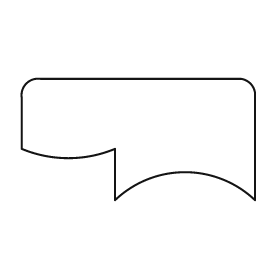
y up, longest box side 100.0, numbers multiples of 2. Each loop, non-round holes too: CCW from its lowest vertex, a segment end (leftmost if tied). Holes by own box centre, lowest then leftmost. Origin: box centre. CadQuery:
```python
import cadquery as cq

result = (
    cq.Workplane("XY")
    .moveTo(-10.0, -26.0)
    .threePointArc((20.0, -14.0), (50.0, -26.0))
    .lineTo(50.0, 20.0)
    .threePointArc((48.0, 24.0), (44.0, 26.0))
    .lineTo(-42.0, 26.0)
    .threePointArc((-48.0, 24.0), (-50.0, 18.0))
    .lineTo(-50.0, -4.0)
    .threePointArc((-30.0, -8.0), (-10.0, -4.0))
    .close()
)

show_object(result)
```